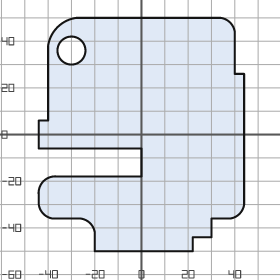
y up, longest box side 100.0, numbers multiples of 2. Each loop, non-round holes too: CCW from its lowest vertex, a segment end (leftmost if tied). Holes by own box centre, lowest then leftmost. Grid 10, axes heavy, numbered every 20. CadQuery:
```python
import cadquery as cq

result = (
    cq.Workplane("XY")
    .moveTo(-20.0, -50.0)
    .lineTo(22.0, -50.0)
    .lineTo(22.0, -44.0)
    .lineTo(30.0, -44.0)
    .lineTo(30.0, -36.0)
    .lineTo(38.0, -36.0)
    .threePointArc((42.0, -34.0), (44.0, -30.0))
    .lineTo(44.0, 26.0)
    .lineTo(40.0, 26.0)
    .lineTo(40.0, 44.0)
    .threePointArc((38.0, 48.0), (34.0, 50.0))
    .lineTo(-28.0, 50.0)
    .threePointArc((-36.0, 46.0), (-40.0, 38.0))
    .lineTo(-40.0, 6.0)
    .lineTo(-44.0, 6.0)
    .lineTo(-44.0, -6.0)
    .lineTo(0.0, -6.0)
    .lineTo(0.0, -18.0)
    .lineTo(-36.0, -18.0)
    .threePointArc((-42.0, -20.0), (-44.0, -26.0))
    .lineTo(-44.0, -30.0)
    .threePointArc((-42.0, -34.0), (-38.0, -36.0))
    .lineTo(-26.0, -36.0)
    .threePointArc((-22.0, -38.0), (-20.0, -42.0))
    .close()
    .moveTo(-30.0, 36.0)
    .circle(6.0)
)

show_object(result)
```